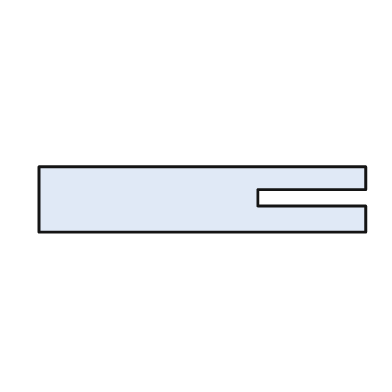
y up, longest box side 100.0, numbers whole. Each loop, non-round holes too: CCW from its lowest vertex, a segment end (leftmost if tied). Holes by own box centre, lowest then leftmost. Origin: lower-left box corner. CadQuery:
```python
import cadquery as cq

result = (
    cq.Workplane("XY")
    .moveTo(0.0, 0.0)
    .lineTo(100.0, 0.0)
    .lineTo(100.0, 8.0)
    .lineTo(67.0, 8.0)
    .lineTo(67.0, 13.0)
    .lineTo(100.0, 13.0)
    .lineTo(100.0, 20.0)
    .lineTo(0.0, 20.0)
    .close()
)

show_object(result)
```